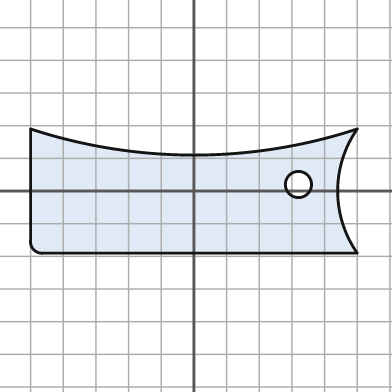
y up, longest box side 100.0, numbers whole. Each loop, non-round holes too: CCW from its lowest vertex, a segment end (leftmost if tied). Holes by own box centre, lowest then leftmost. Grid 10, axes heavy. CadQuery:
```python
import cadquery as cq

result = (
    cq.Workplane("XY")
    .moveTo(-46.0, -19.0)
    .lineTo(50.0, -19.0)
    .threePointArc((44.0, 0.0), (50.0, 19.0))
    .threePointArc((0.0, 11.0), (-50.0, 19.0))
    .lineTo(-50.0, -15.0)
    .threePointArc((-49.0, -18.0), (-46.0, -19.0))
    .close()
    .moveTo(32.0, 2.0)
    .circle(4.0)
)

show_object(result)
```